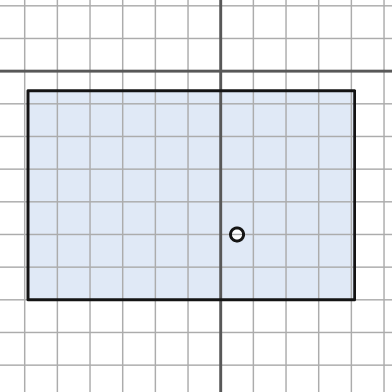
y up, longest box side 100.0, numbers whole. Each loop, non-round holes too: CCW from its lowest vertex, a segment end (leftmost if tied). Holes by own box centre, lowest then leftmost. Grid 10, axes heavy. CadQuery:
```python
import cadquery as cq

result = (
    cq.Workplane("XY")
    .moveTo(-59.0, -70.0)
    .lineTo(41.0, -70.0)
    .lineTo(41.0, -6.0)
    .lineTo(-59.0, -6.0)
    .close()
    .moveTo(5.0, -50.0)
    .circle(2.0)
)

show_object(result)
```